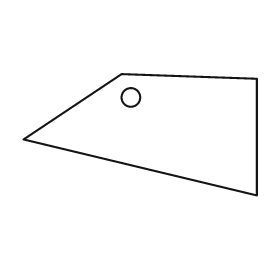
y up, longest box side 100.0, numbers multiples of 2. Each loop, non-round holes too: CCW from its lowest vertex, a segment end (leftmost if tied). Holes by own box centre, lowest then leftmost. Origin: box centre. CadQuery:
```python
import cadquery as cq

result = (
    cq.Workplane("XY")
    .moveTo(50.0, -26.0)
    .lineTo(50.0, 24.0)
    .lineTo(-8.0, 26.0)
    .lineTo(-50.0, -2.0)
    .close()
    .moveTo(-4.0, 16.0)
    .circle(4.0)
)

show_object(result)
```